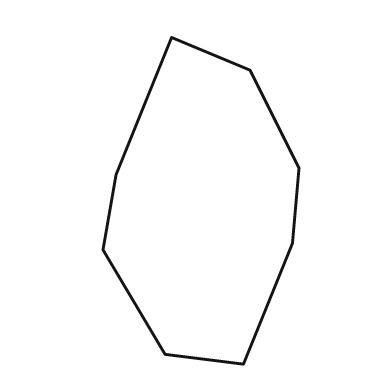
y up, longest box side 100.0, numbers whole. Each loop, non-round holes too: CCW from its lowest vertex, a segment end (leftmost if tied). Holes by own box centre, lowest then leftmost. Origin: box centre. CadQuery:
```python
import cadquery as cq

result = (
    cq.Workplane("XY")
    .moveTo(13.0, -50.0)
    .lineTo(28.0, -13.0)
    .lineTo(30.0, 10.0)
    .lineTo(15.0, 40.0)
    .lineTo(-9.0, 50.0)
    .lineTo(-26.0, 8.0)
    .lineTo(-30.0, -15.0)
    .lineTo(-11.0, -47.0)
    .close()
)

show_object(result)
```